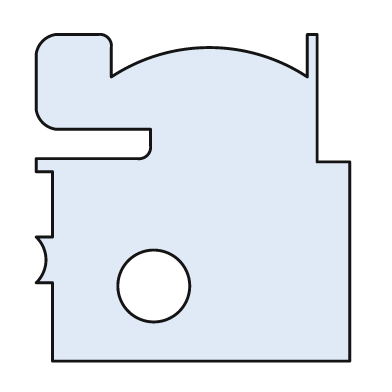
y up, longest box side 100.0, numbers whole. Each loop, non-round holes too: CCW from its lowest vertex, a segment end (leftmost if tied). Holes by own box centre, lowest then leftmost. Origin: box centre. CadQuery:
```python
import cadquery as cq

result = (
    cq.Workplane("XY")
    .moveTo(-43.0, -50.0)
    .lineTo(48.0, -50.0)
    .lineTo(48.0, 11.0)
    .lineTo(38.0, 11.0)
    .lineTo(38.0, 50.0)
    .lineTo(35.0, 50.0)
    .lineTo(35.0, 37.0)
    .threePointArc((5.0, 46.0), (-25.0, 37.0))
    .lineTo(-25.0, 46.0)
    .threePointArc((-26.0, 49.0), (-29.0, 50.0))
    .lineTo(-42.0, 50.0)
    .threePointArc((-46.0, 48.0), (-48.0, 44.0))
    .lineTo(-48.0, 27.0)
    .threePointArc((-46.0, 23.0), (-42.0, 21.0))
    .lineTo(-13.0, 21.0)
    .lineTo(-13.0, 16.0)
    .threePointArc((-14.0, 13.0), (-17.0, 12.0))
    .lineTo(-48.0, 12.0)
    .lineTo(-48.0, 8.0)
    .lineTo(-43.0, 8.0)
    .lineTo(-43.0, -12.0)
    .lineTo(-48.0, -12.0)
    .threePointArc((-45.0, -19.0), (-48.0, -26.0))
    .lineTo(-43.0, -26.0)
    .close()
    .moveTo(-12.0, -27.0)
    .circle(11.0)
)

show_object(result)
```